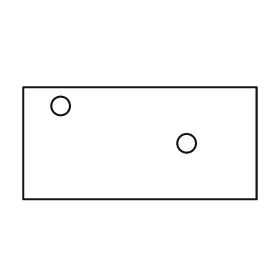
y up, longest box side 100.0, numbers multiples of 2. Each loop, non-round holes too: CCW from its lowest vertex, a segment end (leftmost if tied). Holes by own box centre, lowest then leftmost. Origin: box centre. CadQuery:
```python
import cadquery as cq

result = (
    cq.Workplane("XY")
    .moveTo(-50.0, -24.0)
    .lineTo(50.0, -24.0)
    .lineTo(50.0, 24.0)
    .lineTo(-50.0, 24.0)
    .close()
    .moveTo(20.0, 0.0)
    .circle(4.0)
    .moveTo(-34.0, 16.0)
    .circle(4.0)
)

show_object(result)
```